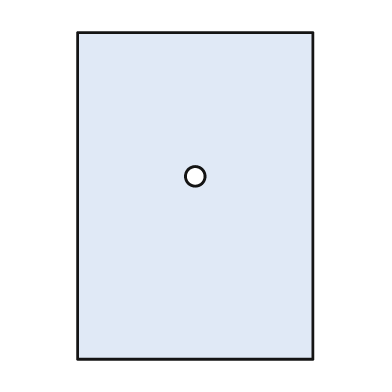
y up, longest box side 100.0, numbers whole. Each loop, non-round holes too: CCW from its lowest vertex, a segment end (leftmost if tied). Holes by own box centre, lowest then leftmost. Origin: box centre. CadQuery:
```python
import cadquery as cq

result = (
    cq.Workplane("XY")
    .moveTo(-36.0, -50.0)
    .lineTo(36.0, -50.0)
    .lineTo(36.0, 50.0)
    .lineTo(-36.0, 50.0)
    .close()
    .moveTo(0.0, 6.0)
    .circle(3.0)
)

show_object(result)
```